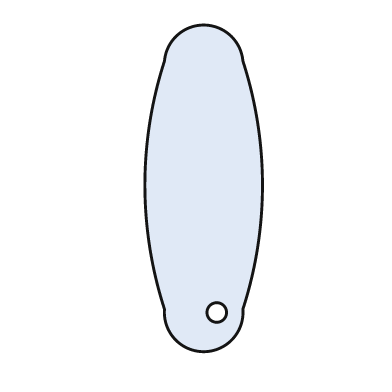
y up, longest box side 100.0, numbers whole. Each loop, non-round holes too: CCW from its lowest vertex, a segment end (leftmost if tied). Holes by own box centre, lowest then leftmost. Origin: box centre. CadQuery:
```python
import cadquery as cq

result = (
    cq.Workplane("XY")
    .moveTo(-12.0, -37.0)
    .threePointArc((0.0, -50.0), (12.0, -37.0))
    .threePointArc((18.0, 1.0), (12.0, 39.0))
    .threePointArc((0.0, 50.0), (-12.0, 39.0))
    .threePointArc((-18.0, 1.0), (-12.0, -37.0))
    .close()
    .moveTo(4.0, -38.0)
    .circle(3.0)
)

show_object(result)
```